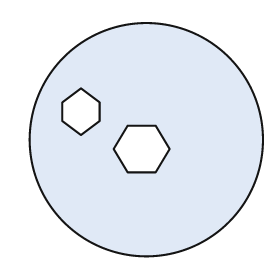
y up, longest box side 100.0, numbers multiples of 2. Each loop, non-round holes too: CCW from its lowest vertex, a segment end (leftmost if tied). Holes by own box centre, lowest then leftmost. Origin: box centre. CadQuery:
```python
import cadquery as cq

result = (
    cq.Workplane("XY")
    .moveTo(0.0, 0.0)
    .circle(50.0)
    .moveTo(-8.0, -14.0)
    .lineTo(4.0, -14.0)
    .lineTo(10.0, -4.0)
    .lineTo(4.0, 6.0)
    .lineTo(-8.0, 6.0)
    .lineTo(-14.0, -4.0)
    .close()
    .moveTo(-28.0, 2.0)
    .lineTo(-20.0, 8.0)
    .lineTo(-20.0, 16.0)
    .lineTo(-28.0, 22.0)
    .lineTo(-36.0, 16.0)
    .lineTo(-36.0, 8.0)
    .close()
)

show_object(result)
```